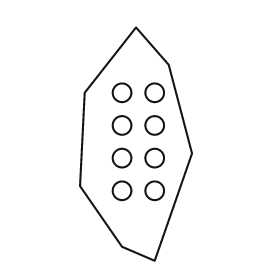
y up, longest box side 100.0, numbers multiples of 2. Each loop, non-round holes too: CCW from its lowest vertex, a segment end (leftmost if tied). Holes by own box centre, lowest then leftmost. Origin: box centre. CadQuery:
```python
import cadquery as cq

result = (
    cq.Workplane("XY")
    .moveTo(8.0, -50.0)
    .lineTo(24.0, -4.0)
    .lineTo(14.0, 34.0)
    .lineTo(0.0, 50.0)
    .lineTo(-22.0, 22.0)
    .lineTo(-24.0, -18.0)
    .lineTo(-6.0, -44.0)
    .close()
    .moveTo(-6.0, -20.0)
    .circle(4.0)
    .moveTo(8.0, -20.0)
    .circle(4.0)
    .moveTo(-6.0, -6.0)
    .circle(4.0)
    .moveTo(8.0, -6.0)
    .circle(4.0)
    .moveTo(-6.0, 8.0)
    .circle(4.0)
    .moveTo(8.0, 8.0)
    .circle(4.0)
    .moveTo(-6.0, 22.0)
    .circle(4.0)
    .moveTo(8.0, 22.0)
    .circle(4.0)
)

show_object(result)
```